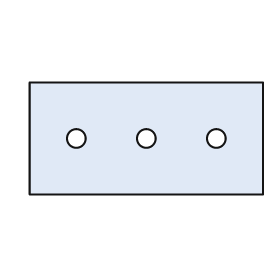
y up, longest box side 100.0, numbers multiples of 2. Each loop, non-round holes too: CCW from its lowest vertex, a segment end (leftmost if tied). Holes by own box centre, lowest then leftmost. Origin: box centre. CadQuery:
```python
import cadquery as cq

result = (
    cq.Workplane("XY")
    .moveTo(-50.0, -24.0)
    .lineTo(50.0, -24.0)
    .lineTo(50.0, 24.0)
    .lineTo(-50.0, 24.0)
    .close()
    .moveTo(-30.0, 0.0)
    .circle(4.0)
    .moveTo(0.0, 0.0)
    .circle(4.0)
    .moveTo(30.0, 0.0)
    .circle(4.0)
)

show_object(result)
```